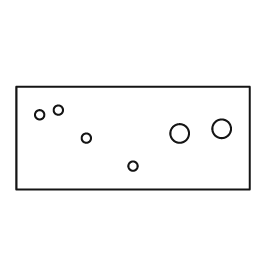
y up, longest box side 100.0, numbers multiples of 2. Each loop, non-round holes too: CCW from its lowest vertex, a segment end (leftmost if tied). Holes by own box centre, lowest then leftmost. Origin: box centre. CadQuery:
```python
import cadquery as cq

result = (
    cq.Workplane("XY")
    .moveTo(-50.0, -22.0)
    .lineTo(50.0, -22.0)
    .lineTo(50.0, 22.0)
    .lineTo(-50.0, 22.0)
    .close()
    .moveTo(0.0, -12.0)
    .circle(2.0)
    .moveTo(-20.0, 0.0)
    .circle(2.0)
    .moveTo(20.0, 2.0)
    .circle(4.0)
    .moveTo(38.0, 4.0)
    .circle(4.0)
    .moveTo(-40.0, 10.0)
    .circle(2.0)
    .moveTo(-32.0, 12.0)
    .circle(2.0)
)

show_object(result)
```